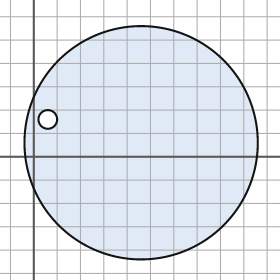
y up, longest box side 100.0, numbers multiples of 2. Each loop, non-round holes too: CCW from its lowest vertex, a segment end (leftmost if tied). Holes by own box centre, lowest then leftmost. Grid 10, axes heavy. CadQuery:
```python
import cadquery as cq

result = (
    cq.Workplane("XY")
    .moveTo(46.0, 6.0)
    .circle(50.0)
    .moveTo(6.0, 16.0)
    .circle(4.0)
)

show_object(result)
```